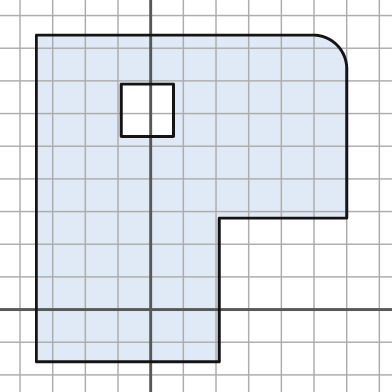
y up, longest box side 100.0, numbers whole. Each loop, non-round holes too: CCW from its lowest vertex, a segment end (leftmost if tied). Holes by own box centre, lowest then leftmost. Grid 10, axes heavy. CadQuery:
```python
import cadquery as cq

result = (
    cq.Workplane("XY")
    .moveTo(-35.0, -16.0)
    .lineTo(21.0, -16.0)
    .lineTo(21.0, 28.0)
    .lineTo(60.0, 28.0)
    .lineTo(60.0, 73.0)
    .threePointArc((57.0, 81.0), (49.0, 84.0))
    .lineTo(-35.0, 84.0)
    .close()
    .moveTo(-9.0, 53.0)
    .lineTo(7.0, 53.0)
    .lineTo(7.0, 69.0)
    .lineTo(-9.0, 69.0)
    .close()
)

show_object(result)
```